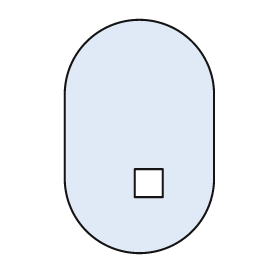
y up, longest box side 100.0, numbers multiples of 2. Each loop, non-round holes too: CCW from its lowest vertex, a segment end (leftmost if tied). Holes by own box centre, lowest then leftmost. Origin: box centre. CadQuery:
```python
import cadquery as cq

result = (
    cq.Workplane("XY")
    .moveTo(-32.0, -18.0)
    .threePointArc((0.0, -50.0), (32.0, -18.0))
    .lineTo(32.0, 18.0)
    .threePointArc((0.0, 50.0), (-32.0, 18.0))
    .close()
    .moveTo(-2.0, -26.0)
    .lineTo(10.0, -26.0)
    .lineTo(10.0, -14.0)
    .lineTo(-2.0, -14.0)
    .close()
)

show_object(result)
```